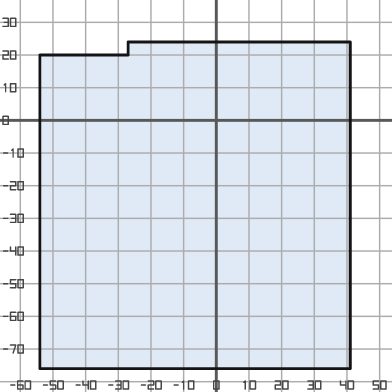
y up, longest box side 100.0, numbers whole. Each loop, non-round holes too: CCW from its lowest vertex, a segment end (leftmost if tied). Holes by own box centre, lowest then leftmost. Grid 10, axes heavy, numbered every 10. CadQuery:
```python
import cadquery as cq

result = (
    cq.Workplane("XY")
    .moveTo(-54.0, -76.0)
    .lineTo(41.0, -76.0)
    .lineTo(41.0, 24.0)
    .lineTo(-27.0, 24.0)
    .lineTo(-27.0, 20.0)
    .lineTo(-54.0, 20.0)
    .close()
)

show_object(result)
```